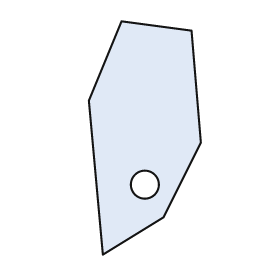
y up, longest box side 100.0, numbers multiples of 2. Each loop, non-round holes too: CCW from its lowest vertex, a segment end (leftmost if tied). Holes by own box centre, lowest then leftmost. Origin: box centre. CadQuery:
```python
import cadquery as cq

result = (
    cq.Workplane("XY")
    .moveTo(-18.0, -50.0)
    .lineTo(8.0, -34.0)
    .lineTo(24.0, -2.0)
    .lineTo(20.0, 46.0)
    .lineTo(-10.0, 50.0)
    .lineTo(-24.0, 16.0)
    .close()
    .moveTo(0.0, -20.0)
    .circle(6.0)
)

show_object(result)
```